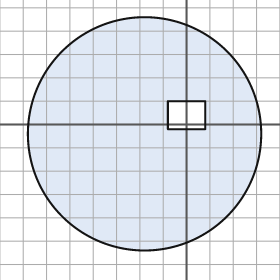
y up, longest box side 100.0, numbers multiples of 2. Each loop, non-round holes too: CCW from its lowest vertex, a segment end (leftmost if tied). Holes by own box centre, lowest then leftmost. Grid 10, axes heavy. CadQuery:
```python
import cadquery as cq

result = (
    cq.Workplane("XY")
    .moveTo(-18.0, -4.0)
    .circle(50.0)
    .moveTo(-8.0, -2.0)
    .lineTo(8.0, -2.0)
    .lineTo(8.0, 10.0)
    .lineTo(-8.0, 10.0)
    .close()
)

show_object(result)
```